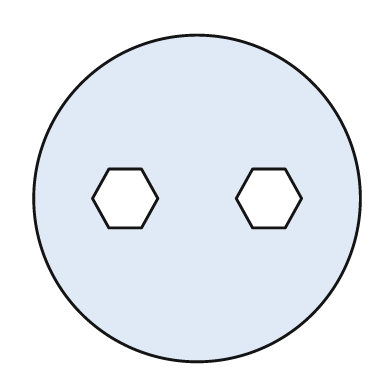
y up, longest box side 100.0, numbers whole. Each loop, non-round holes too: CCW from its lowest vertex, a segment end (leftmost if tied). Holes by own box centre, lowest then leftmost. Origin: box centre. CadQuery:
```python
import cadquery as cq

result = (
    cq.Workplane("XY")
    .moveTo(0.0, 0.0)
    .circle(50.0)
    .moveTo(-27.0, -9.0)
    .lineTo(-17.0, -9.0)
    .lineTo(-12.0, 0.0)
    .lineTo(-17.0, 9.0)
    .lineTo(-27.0, 9.0)
    .lineTo(-32.0, 0.0)
    .close()
    .moveTo(17.0, -9.0)
    .lineTo(27.0, -9.0)
    .lineTo(32.0, 0.0)
    .lineTo(27.0, 9.0)
    .lineTo(17.0, 9.0)
    .lineTo(12.0, 0.0)
    .close()
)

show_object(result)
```